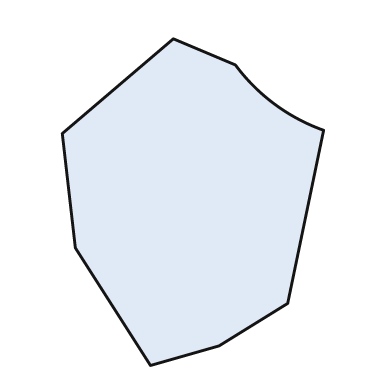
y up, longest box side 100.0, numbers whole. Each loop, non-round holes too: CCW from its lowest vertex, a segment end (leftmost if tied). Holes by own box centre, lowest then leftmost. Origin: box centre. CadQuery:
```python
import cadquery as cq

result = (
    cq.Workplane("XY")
    .moveTo(-13.0, -50.0)
    .lineTo(8.0, -44.0)
    .lineTo(29.0, -31.0)
    .lineTo(40.0, 22.0)
    .threePointArc((25.0, 30.0), (13.0, 42.0))
    .lineTo(-6.0, 50.0)
    .lineTo(-40.0, 21.0)
    .lineTo(-36.0, -14.0)
    .close()
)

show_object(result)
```